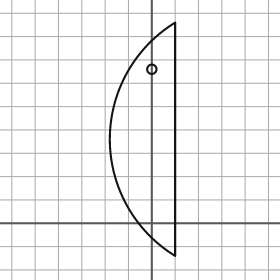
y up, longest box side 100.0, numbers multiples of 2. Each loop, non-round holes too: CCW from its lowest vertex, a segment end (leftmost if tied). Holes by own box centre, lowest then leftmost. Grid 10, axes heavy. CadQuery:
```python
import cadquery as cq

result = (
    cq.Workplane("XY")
    .moveTo(10.0, -14.0)
    .lineTo(10.0, 86.0)
    .threePointArc((-18.0, 36.0), (10.0, -14.0))
    .close()
    .moveTo(0.0, 66.0)
    .circle(2.0)
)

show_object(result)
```